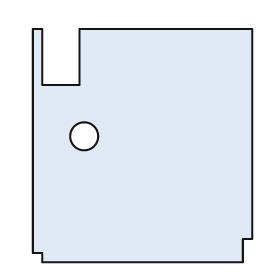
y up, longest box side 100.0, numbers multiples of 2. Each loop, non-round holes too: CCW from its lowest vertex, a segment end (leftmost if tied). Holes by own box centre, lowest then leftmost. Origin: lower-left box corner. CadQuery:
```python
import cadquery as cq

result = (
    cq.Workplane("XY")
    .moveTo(4.0, 0.0)
    .lineTo(90.0, 0.0)
    .lineTo(90.0, 10.0)
    .lineTo(94.0, 10.0)
    .lineTo(94.0, 100.0)
    .lineTo(20.0, 100.0)
    .lineTo(20.0, 76.0)
    .lineTo(4.0, 76.0)
    .lineTo(4.0, 100.0)
    .lineTo(0.0, 100.0)
    .lineTo(0.0, 4.0)
    .lineTo(4.0, 4.0)
    .close()
    .moveTo(22.0, 54.0)
    .circle(6.0)
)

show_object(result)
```